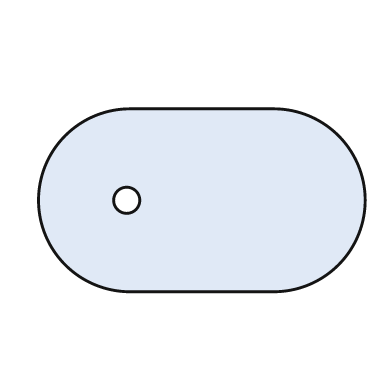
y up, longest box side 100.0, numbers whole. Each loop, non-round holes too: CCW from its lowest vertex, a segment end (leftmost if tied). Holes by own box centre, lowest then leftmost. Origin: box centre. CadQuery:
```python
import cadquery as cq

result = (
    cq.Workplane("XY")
    .moveTo(-22.0, -28.0)
    .lineTo(22.0, -28.0)
    .threePointArc((50.0, 0.0), (22.0, 28.0))
    .lineTo(-22.0, 28.0)
    .threePointArc((-50.0, 0.0), (-22.0, -28.0))
    .close()
    .moveTo(-23.0, 0.0)
    .circle(4.0)
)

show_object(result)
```